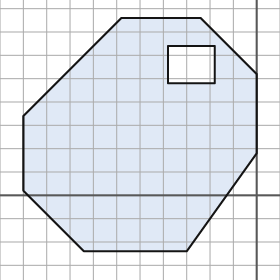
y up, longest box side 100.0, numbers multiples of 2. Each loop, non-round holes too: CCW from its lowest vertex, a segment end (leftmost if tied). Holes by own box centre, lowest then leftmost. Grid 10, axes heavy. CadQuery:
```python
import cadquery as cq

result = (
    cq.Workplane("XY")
    .moveTo(-74.0, -24.0)
    .lineTo(-30.0, -24.0)
    .lineTo(0.0, 18.0)
    .lineTo(0.0, 52.0)
    .lineTo(-24.0, 76.0)
    .lineTo(-58.0, 76.0)
    .lineTo(-100.0, 34.0)
    .lineTo(-100.0, 2.0)
    .close()
    .moveTo(-38.0, 48.0)
    .lineTo(-18.0, 48.0)
    .lineTo(-18.0, 64.0)
    .lineTo(-38.0, 64.0)
    .close()
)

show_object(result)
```